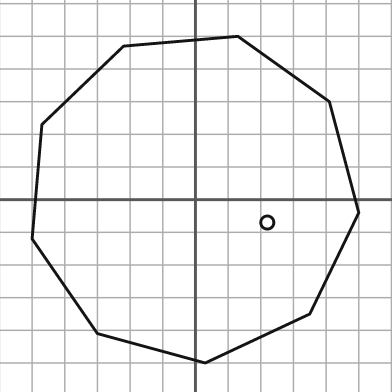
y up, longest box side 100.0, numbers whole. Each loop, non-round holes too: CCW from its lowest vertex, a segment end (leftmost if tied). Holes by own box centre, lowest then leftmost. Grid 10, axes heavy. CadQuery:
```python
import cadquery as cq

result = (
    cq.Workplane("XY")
    .moveTo(3.0, -50.0)
    .lineTo(35.0, -35.0)
    .lineTo(50.0, -4.0)
    .lineTo(41.0, 30.0)
    .lineTo(13.0, 50.0)
    .lineTo(-22.0, 47.0)
    .lineTo(-47.0, 23.0)
    .lineTo(-50.0, -12.0)
    .lineTo(-30.0, -41.0)
    .close()
    .moveTo(22.0, -7.0)
    .circle(2.0)
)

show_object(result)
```